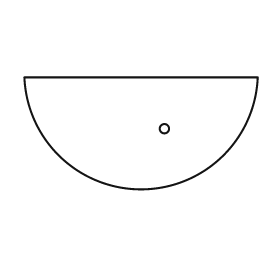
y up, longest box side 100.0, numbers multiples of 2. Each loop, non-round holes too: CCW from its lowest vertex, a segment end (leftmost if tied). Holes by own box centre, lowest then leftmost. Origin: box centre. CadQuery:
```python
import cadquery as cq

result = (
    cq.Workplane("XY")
    .moveTo(-50.0, 24.0)
    .threePointArc((0.0, -24.0), (50.0, 24.0))
    .close()
    .moveTo(10.0, 2.0)
    .circle(2.0)
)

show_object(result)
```